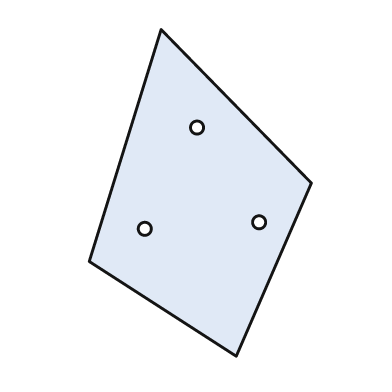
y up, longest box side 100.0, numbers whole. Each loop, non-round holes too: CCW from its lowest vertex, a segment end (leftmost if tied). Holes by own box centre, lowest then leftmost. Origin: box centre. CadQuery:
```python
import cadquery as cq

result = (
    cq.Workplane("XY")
    .moveTo(11.0, -50.0)
    .lineTo(34.0, 3.0)
    .lineTo(-12.0, 50.0)
    .lineTo(-34.0, -21.0)
    .close()
    .moveTo(-17.0, -11.0)
    .circle(2.0)
    .moveTo(18.0, -9.0)
    .circle(2.0)
    .moveTo(-1.0, 20.0)
    .circle(2.0)
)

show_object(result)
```